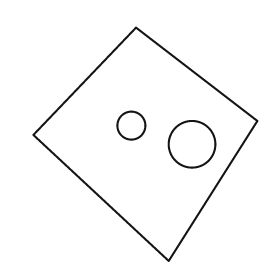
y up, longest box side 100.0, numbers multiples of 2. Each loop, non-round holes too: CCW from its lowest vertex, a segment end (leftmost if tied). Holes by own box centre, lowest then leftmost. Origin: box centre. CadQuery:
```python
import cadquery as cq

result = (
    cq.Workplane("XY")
    .moveTo(10.0, -50.0)
    .lineTo(48.0, 10.0)
    .lineTo(-4.0, 50.0)
    .lineTo(-48.0, 4.0)
    .close()
    .moveTo(20.0, 0.0)
    .circle(10.0)
    .moveTo(-6.0, 8.0)
    .circle(6.0)
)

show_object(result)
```